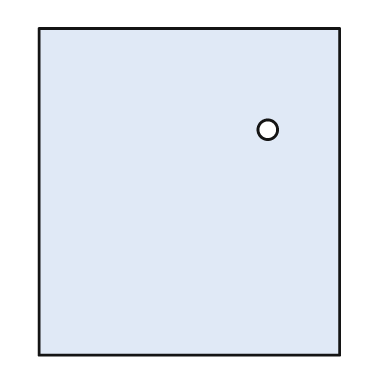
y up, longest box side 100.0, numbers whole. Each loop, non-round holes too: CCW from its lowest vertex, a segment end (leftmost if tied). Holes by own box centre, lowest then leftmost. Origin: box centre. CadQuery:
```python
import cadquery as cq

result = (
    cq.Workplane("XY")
    .moveTo(-46.0, -50.0)
    .lineTo(46.0, -50.0)
    .lineTo(46.0, 50.0)
    .lineTo(-46.0, 50.0)
    .close()
    .moveTo(24.0, 19.0)
    .circle(3.0)
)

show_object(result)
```